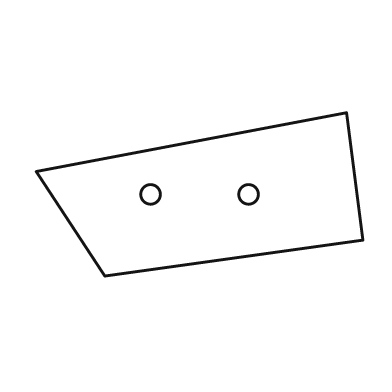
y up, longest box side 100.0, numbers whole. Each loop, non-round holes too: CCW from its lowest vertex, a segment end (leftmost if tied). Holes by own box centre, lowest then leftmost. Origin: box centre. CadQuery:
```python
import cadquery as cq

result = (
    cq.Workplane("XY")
    .moveTo(-29.0, -25.0)
    .lineTo(50.0, -14.0)
    .lineTo(45.0, 25.0)
    .lineTo(-50.0, 7.0)
    .close()
    .moveTo(-15.0, 0.0)
    .circle(3.0)
    .moveTo(15.0, 0.0)
    .circle(3.0)
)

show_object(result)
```